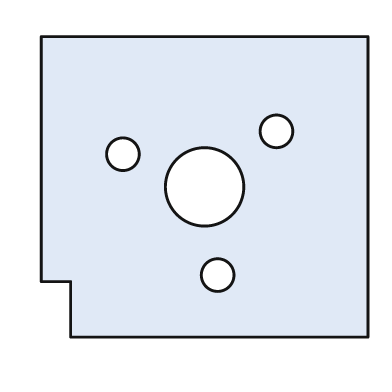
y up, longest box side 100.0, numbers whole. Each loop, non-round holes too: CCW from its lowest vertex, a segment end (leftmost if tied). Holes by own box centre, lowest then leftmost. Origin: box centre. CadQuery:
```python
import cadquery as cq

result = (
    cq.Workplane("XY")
    .moveTo(-41.0, -46.0)
    .lineTo(50.0, -46.0)
    .lineTo(50.0, 46.0)
    .lineTo(-50.0, 46.0)
    .lineTo(-50.0, -29.0)
    .lineTo(-41.0, -29.0)
    .close()
    .moveTo(4.0, -27.0)
    .circle(5.0)
    .moveTo(0.0, 0.0)
    .circle(12.0)
    .moveTo(-25.0, 10.0)
    .circle(5.0)
    .moveTo(22.0, 17.0)
    .circle(5.0)
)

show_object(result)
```